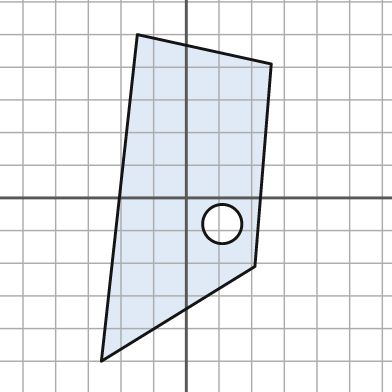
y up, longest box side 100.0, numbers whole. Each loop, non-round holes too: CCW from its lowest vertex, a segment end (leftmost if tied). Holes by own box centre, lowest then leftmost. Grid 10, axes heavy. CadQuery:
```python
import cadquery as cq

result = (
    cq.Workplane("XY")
    .moveTo(-26.0, -50.0)
    .lineTo(21.0, -21.0)
    .lineTo(26.0, 41.0)
    .lineTo(-15.0, 50.0)
    .close()
    .moveTo(11.0, -8.0)
    .circle(6.0)
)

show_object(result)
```